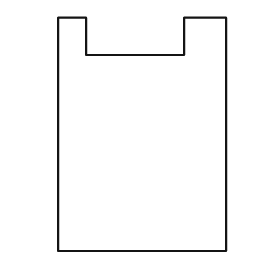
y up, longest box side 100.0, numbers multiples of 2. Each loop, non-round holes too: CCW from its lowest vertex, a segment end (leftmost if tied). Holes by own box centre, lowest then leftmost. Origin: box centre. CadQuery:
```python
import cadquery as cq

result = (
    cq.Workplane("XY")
    .moveTo(-36.0, -50.0)
    .lineTo(36.0, -50.0)
    .lineTo(36.0, 50.0)
    .lineTo(18.0, 50.0)
    .lineTo(18.0, 34.0)
    .lineTo(-24.0, 34.0)
    .lineTo(-24.0, 50.0)
    .lineTo(-36.0, 50.0)
    .close()
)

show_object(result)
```